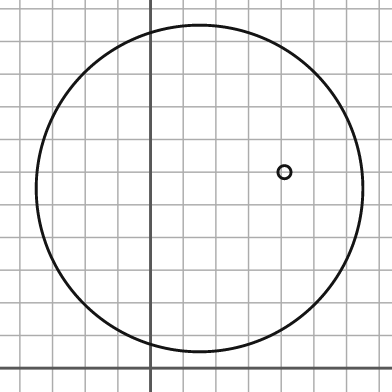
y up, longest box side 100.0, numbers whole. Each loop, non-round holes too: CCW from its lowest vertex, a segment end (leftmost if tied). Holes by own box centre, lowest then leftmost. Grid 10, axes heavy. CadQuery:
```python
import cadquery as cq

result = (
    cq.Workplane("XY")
    .moveTo(15.0, 55.0)
    .circle(50.0)
    .moveTo(41.0, 60.0)
    .circle(2.0)
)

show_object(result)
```